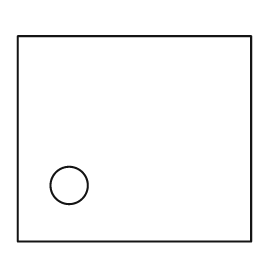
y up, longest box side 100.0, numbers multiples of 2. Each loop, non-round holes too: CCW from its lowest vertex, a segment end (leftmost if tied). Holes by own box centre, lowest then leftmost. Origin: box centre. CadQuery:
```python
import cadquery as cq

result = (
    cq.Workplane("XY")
    .moveTo(-50.0, -44.0)
    .lineTo(50.0, -44.0)
    .lineTo(50.0, 44.0)
    .lineTo(-50.0, 44.0)
    .close()
    .moveTo(-28.0, -20.0)
    .circle(8.0)
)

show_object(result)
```